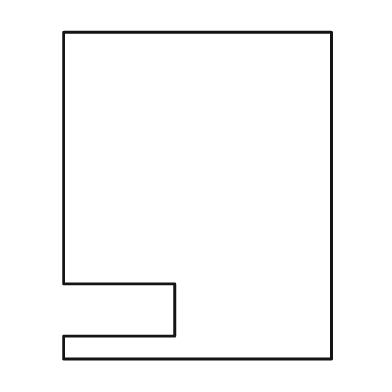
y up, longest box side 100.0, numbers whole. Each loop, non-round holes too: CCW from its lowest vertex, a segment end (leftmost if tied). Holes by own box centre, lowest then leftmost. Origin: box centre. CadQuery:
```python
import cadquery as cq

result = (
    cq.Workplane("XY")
    .moveTo(-41.0, -50.0)
    .lineTo(41.0, -50.0)
    .lineTo(41.0, 50.0)
    .lineTo(-41.0, 50.0)
    .lineTo(-41.0, -27.0)
    .lineTo(-7.0, -27.0)
    .lineTo(-7.0, -43.0)
    .lineTo(-41.0, -43.0)
    .close()
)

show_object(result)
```